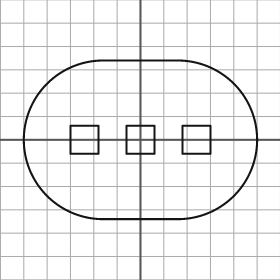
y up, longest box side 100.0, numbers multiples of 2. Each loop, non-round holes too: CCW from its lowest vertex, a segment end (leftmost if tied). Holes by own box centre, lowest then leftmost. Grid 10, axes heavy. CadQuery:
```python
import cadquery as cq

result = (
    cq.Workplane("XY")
    .moveTo(-16.0, -34.0)
    .lineTo(16.0, -34.0)
    .threePointArc((50.0, 0.0), (16.0, 34.0))
    .lineTo(-16.0, 34.0)
    .threePointArc((-50.0, 0.0), (-16.0, -34.0))
    .close()
    .moveTo(-30.0, -6.0)
    .lineTo(-18.0, -6.0)
    .lineTo(-18.0, 6.0)
    .lineTo(-30.0, 6.0)
    .close()
    .moveTo(-6.0, -6.0)
    .lineTo(6.0, -6.0)
    .lineTo(6.0, 6.0)
    .lineTo(-6.0, 6.0)
    .close()
    .moveTo(18.0, -6.0)
    .lineTo(30.0, -6.0)
    .lineTo(30.0, 6.0)
    .lineTo(18.0, 6.0)
    .close()
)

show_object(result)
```